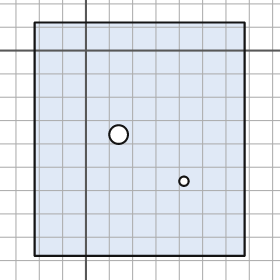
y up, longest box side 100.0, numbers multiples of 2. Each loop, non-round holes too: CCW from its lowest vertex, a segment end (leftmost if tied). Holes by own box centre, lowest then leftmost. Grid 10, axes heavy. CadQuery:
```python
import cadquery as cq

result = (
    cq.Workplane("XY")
    .moveTo(-22.0, -88.0)
    .lineTo(68.0, -88.0)
    .lineTo(68.0, 12.0)
    .lineTo(-22.0, 12.0)
    .close()
    .moveTo(42.0, -56.0)
    .circle(2.0)
    .moveTo(14.0, -36.0)
    .circle(4.0)
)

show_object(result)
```